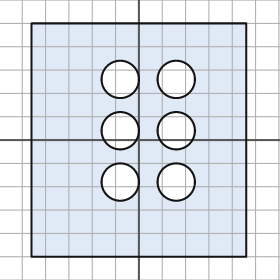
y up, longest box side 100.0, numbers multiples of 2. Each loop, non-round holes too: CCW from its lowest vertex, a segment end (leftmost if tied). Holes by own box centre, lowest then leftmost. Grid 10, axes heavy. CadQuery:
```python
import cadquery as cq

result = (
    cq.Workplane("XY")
    .moveTo(-46.0, -50.0)
    .lineTo(46.0, -50.0)
    .lineTo(46.0, 50.0)
    .lineTo(-46.0, 50.0)
    .close()
    .moveTo(-8.0, -18.0)
    .circle(8.0)
    .moveTo(16.0, -18.0)
    .circle(8.0)
    .moveTo(-8.0, 4.0)
    .circle(8.0)
    .moveTo(16.0, 4.0)
    .circle(8.0)
    .moveTo(-8.0, 26.0)
    .circle(8.0)
    .moveTo(16.0, 26.0)
    .circle(8.0)
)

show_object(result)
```